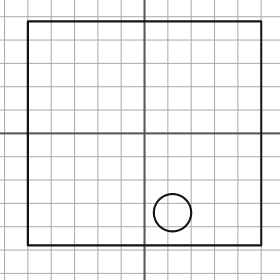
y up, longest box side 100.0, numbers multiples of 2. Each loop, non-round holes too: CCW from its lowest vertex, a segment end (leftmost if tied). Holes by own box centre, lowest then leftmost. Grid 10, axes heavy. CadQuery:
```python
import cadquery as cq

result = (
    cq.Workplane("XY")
    .moveTo(-50.0, -48.0)
    .lineTo(50.0, -48.0)
    .lineTo(50.0, 48.0)
    .lineTo(-50.0, 48.0)
    .close()
    .moveTo(12.0, -34.0)
    .circle(8.0)
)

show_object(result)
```